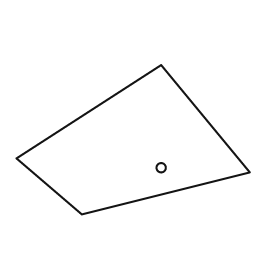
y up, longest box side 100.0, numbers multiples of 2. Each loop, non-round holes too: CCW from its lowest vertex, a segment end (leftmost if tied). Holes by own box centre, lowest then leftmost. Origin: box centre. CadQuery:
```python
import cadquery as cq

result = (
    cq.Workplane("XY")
    .moveTo(-22.0, -32.0)
    .lineTo(50.0, -14.0)
    .lineTo(12.0, 32.0)
    .lineTo(-50.0, -8.0)
    .close()
    .moveTo(12.0, -12.0)
    .circle(2.0)
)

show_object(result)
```